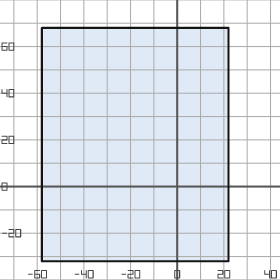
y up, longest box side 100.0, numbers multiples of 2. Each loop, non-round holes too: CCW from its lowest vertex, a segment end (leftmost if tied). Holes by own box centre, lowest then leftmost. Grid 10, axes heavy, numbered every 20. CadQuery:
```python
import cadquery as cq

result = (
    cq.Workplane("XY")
    .moveTo(-58.0, -32.0)
    .lineTo(22.0, -32.0)
    .lineTo(22.0, 68.0)
    .lineTo(-58.0, 68.0)
    .close()
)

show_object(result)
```